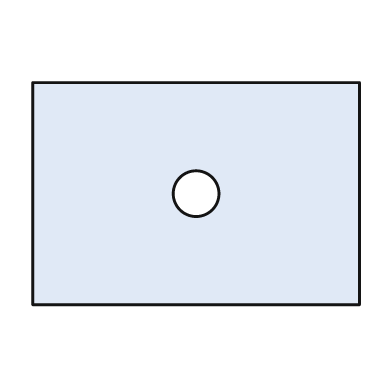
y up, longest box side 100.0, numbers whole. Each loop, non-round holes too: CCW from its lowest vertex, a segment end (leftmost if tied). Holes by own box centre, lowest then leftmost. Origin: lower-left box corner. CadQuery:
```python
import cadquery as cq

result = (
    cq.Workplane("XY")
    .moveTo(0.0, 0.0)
    .lineTo(100.0, 0.0)
    .lineTo(100.0, 68.0)
    .lineTo(0.0, 68.0)
    .close()
    .moveTo(50.0, 34.0)
    .circle(7.0)
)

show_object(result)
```